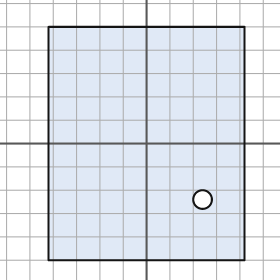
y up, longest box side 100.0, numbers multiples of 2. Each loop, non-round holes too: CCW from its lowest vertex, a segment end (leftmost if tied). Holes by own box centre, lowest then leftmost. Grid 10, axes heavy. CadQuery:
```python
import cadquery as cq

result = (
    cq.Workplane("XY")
    .moveTo(-42.0, -50.0)
    .lineTo(42.0, -50.0)
    .lineTo(42.0, 50.0)
    .lineTo(-42.0, 50.0)
    .close()
    .moveTo(24.0, -24.0)
    .circle(4.0)
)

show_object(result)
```